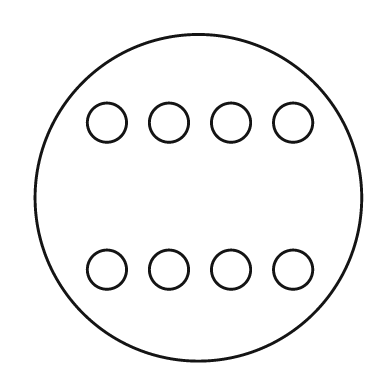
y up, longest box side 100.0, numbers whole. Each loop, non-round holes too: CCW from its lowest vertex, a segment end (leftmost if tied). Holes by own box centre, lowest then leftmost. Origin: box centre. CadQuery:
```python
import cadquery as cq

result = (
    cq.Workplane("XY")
    .moveTo(0.0, 0.0)
    .circle(50.0)
    .moveTo(-28.0, -22.0)
    .circle(6.0)
    .moveTo(-9.0, -22.0)
    .circle(6.0)
    .moveTo(10.0, -22.0)
    .circle(6.0)
    .moveTo(29.0, -22.0)
    .circle(6.0)
    .moveTo(-28.0, 23.0)
    .circle(6.0)
    .moveTo(-9.0, 23.0)
    .circle(6.0)
    .moveTo(10.0, 23.0)
    .circle(6.0)
    .moveTo(29.0, 23.0)
    .circle(6.0)
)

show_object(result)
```